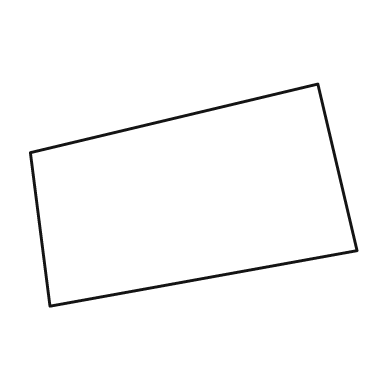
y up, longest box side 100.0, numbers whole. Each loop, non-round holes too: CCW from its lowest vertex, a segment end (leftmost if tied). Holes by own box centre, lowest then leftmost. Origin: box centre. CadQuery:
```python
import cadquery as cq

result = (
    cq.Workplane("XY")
    .moveTo(-44.0, -34.0)
    .lineTo(50.0, -17.0)
    .lineTo(38.0, 34.0)
    .lineTo(-50.0, 13.0)
    .close()
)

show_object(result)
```